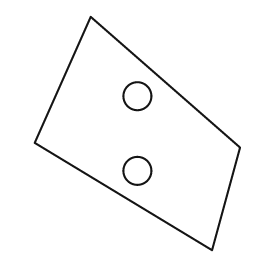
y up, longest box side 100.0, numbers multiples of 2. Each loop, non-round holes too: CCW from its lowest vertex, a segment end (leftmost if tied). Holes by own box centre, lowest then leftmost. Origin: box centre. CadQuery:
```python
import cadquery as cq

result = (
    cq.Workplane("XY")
    .moveTo(32.0, -50.0)
    .lineTo(44.0, -6.0)
    .lineTo(-20.0, 50.0)
    .lineTo(-44.0, -4.0)
    .close()
    .moveTo(0.0, -16.0)
    .circle(6.0)
    .moveTo(0.0, 16.0)
    .circle(6.0)
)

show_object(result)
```